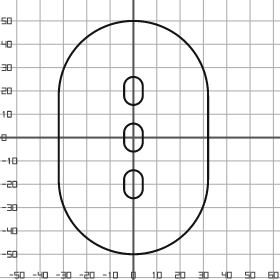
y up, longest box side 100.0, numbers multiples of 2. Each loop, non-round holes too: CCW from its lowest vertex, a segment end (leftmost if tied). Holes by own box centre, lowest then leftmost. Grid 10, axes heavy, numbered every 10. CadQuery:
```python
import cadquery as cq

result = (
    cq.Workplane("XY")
    .moveTo(-32.0, -18.0)
    .threePointArc((0.0, -50.0), (32.0, -18.0))
    .lineTo(32.0, 18.0)
    .threePointArc((0.0, 50.0), (-32.0, 18.0))
    .close()
    .moveTo(-4.0, -22.0)
    .threePointArc((0.0, -26.0), (4.0, -22.0))
    .lineTo(4.0, -18.0)
    .threePointArc((0.0, -14.0), (-4.0, -18.0))
    .close()
    .moveTo(-4.0, -2.0)
    .threePointArc((0.0, -6.0), (4.0, -2.0))
    .lineTo(4.0, 2.0)
    .threePointArc((0.0, 6.0), (-4.0, 2.0))
    .close()
    .moveTo(-4.0, 18.0)
    .threePointArc((0.0, 14.0), (4.0, 18.0))
    .lineTo(4.0, 22.0)
    .threePointArc((0.0, 26.0), (-4.0, 22.0))
    .close()
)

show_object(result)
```